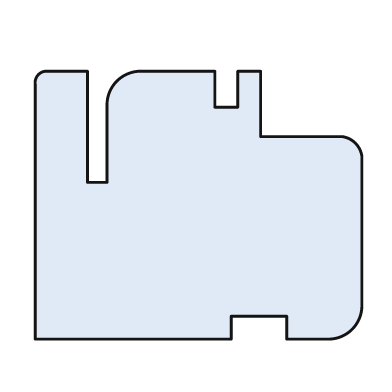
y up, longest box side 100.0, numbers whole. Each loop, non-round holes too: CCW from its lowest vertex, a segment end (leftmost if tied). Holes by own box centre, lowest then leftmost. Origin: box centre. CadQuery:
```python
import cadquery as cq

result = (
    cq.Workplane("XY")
    .moveTo(-50.0, -41.0)
    .lineTo(10.0, -41.0)
    .lineTo(10.0, -34.0)
    .lineTo(27.0, -34.0)
    .lineTo(27.0, -41.0)
    .lineTo(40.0, -41.0)
    .threePointArc((47.0, -38.0), (50.0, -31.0))
    .lineTo(50.0, 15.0)
    .threePointArc((48.0, 19.0), (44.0, 21.0))
    .lineTo(19.0, 21.0)
    .lineTo(19.0, 41.0)
    .lineTo(12.0, 41.0)
    .lineTo(12.0, 30.0)
    .lineTo(5.0, 30.0)
    .lineTo(5.0, 41.0)
    .lineTo(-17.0, 41.0)
    .threePointArc((-25.0, 38.0), (-28.0, 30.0))
    .lineTo(-28.0, 7.0)
    .lineTo(-34.0, 7.0)
    .lineTo(-34.0, 41.0)
    .lineTo(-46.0, 41.0)
    .threePointArc((-49.0, 40.0), (-50.0, 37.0))
    .close()
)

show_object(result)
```